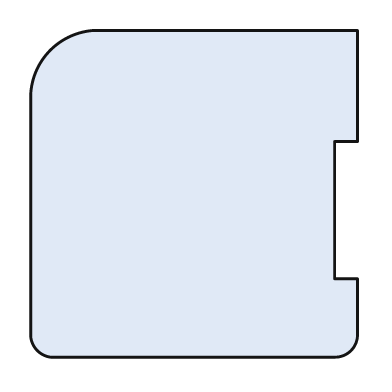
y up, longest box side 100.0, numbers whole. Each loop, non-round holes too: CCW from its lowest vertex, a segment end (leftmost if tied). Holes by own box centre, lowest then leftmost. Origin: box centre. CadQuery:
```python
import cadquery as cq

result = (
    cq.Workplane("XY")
    .moveTo(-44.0, -50.0)
    .lineTo(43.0, -50.0)
    .threePointArc((48.0, -48.0), (50.0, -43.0))
    .lineTo(50.0, -26.0)
    .lineTo(43.0, -26.0)
    .lineTo(43.0, 16.0)
    .lineTo(50.0, 16.0)
    .lineTo(50.0, 50.0)
    .lineTo(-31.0, 50.0)
    .threePointArc((-44.0, 44.0), (-50.0, 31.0))
    .lineTo(-50.0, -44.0)
    .threePointArc((-48.0, -48.0), (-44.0, -50.0))
    .close()
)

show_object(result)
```